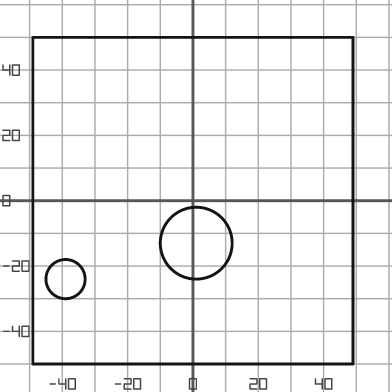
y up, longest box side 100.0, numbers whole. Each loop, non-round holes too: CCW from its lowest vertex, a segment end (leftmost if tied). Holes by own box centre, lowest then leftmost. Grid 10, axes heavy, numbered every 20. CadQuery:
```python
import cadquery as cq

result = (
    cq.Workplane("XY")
    .moveTo(-49.0, -50.0)
    .lineTo(49.0, -50.0)
    .lineTo(49.0, 50.0)
    .lineTo(-49.0, 50.0)
    .close()
    .moveTo(-39.0, -24.0)
    .circle(6.0)
    .moveTo(1.0, -13.0)
    .circle(11.0)
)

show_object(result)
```